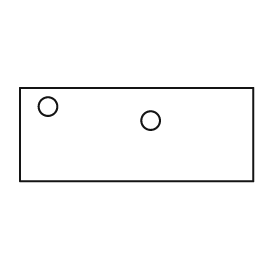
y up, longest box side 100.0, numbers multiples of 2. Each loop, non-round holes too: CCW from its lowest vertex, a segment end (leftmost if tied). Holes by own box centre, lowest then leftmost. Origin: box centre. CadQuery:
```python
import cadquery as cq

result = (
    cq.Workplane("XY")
    .moveTo(-50.0, -20.0)
    .lineTo(50.0, -20.0)
    .lineTo(50.0, 20.0)
    .lineTo(-50.0, 20.0)
    .close()
    .moveTo(6.0, 6.0)
    .circle(4.0)
    .moveTo(-38.0, 12.0)
    .circle(4.0)
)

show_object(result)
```